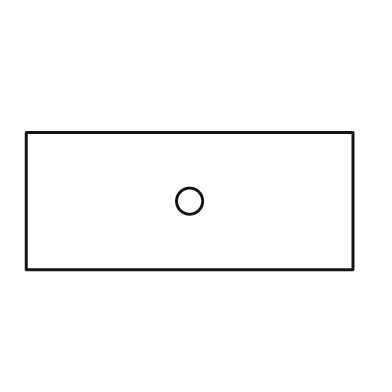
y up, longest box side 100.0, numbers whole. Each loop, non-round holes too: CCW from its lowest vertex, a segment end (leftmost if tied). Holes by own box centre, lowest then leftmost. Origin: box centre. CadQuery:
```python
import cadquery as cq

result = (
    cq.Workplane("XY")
    .moveTo(-50.0, -21.0)
    .lineTo(50.0, -21.0)
    .lineTo(50.0, 21.0)
    .lineTo(-50.0, 21.0)
    .close()
    .moveTo(0.0, 0.0)
    .circle(4.0)
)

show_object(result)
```